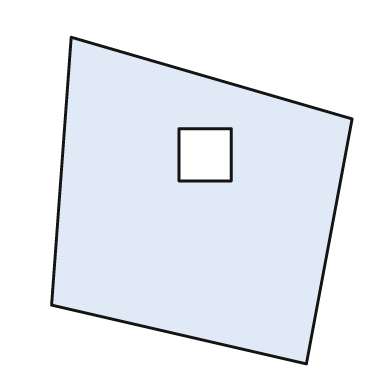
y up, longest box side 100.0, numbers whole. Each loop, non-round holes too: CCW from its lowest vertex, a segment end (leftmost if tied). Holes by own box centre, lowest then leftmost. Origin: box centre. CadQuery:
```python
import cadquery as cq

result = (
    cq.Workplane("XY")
    .moveTo(32.0, -50.0)
    .lineTo(46.0, 25.0)
    .lineTo(-40.0, 50.0)
    .lineTo(-46.0, -32.0)
    .close()
    .moveTo(-7.0, 6.0)
    .lineTo(9.0, 6.0)
    .lineTo(9.0, 22.0)
    .lineTo(-7.0, 22.0)
    .close()
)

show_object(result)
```